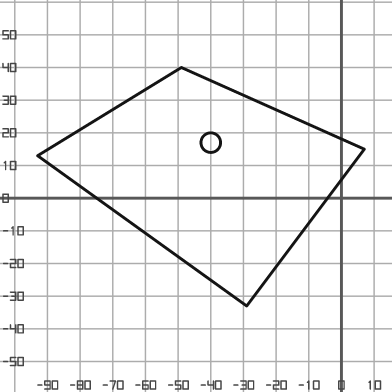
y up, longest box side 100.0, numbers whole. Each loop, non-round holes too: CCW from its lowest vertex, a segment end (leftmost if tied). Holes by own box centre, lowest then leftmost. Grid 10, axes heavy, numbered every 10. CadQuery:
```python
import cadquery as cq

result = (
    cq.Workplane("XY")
    .moveTo(-29.0, -33.0)
    .lineTo(7.0, 15.0)
    .lineTo(-49.0, 40.0)
    .lineTo(-93.0, 13.0)
    .close()
    .moveTo(-40.0, 17.0)
    .circle(3.0)
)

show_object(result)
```